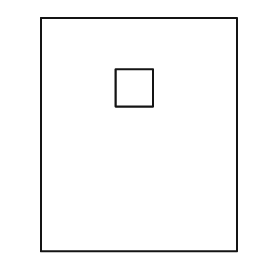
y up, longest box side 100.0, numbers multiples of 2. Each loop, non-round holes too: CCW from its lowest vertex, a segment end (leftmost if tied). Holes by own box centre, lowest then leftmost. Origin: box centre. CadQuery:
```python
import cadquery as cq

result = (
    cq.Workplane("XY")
    .moveTo(-42.0, -50.0)
    .lineTo(42.0, -50.0)
    .lineTo(42.0, 50.0)
    .lineTo(-42.0, 50.0)
    .close()
    .moveTo(-10.0, 12.0)
    .lineTo(6.0, 12.0)
    .lineTo(6.0, 28.0)
    .lineTo(-10.0, 28.0)
    .close()
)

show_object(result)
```